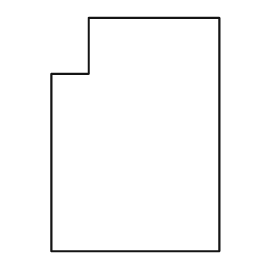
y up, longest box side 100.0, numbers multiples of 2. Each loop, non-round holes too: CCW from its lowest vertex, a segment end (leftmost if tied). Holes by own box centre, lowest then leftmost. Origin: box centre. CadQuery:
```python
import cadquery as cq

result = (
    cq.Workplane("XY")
    .moveTo(-36.0, -50.0)
    .lineTo(36.0, -50.0)
    .lineTo(36.0, 50.0)
    .lineTo(-20.0, 50.0)
    .lineTo(-20.0, 26.0)
    .lineTo(-36.0, 26.0)
    .close()
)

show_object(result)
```